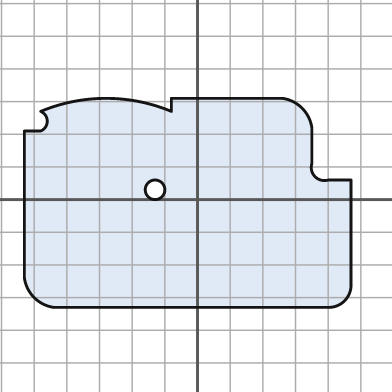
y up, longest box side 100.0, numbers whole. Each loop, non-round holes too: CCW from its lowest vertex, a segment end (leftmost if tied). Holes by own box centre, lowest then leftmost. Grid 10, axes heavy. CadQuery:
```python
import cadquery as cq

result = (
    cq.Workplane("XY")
    .moveTo(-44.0, -33.0)
    .lineTo(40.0, -33.0)
    .threePointArc((45.0, -31.0), (47.0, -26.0))
    .lineTo(47.0, 6.0)
    .lineTo(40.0, 6.0)
    .threePointArc((36.0, 7.0), (35.0, 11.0))
    .lineTo(35.0, 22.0)
    .threePointArc((32.0, 28.0), (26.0, 31.0))
    .lineTo(-8.0, 31.0)
    .lineTo(-8.0, 27.0)
    .threePointArc((-28.0, 31.0), (-48.0, 27.0))
    .threePointArc((-46.0, 24.0), (-48.0, 21.0))
    .lineTo(-53.0, 21.0)
    .lineTo(-53.0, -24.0)
    .threePointArc((-50.0, -30.0), (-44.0, -33.0))
    .close()
    .moveTo(-13.0, 3.0)
    .circle(3.0)
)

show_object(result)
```